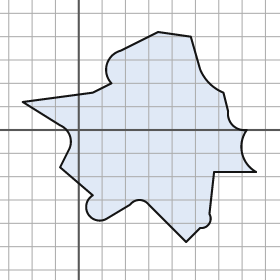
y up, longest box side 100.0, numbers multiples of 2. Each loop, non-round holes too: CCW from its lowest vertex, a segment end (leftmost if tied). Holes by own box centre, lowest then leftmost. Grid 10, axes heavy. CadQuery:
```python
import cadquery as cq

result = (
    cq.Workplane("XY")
    .moveTo(46.0, -48.0)
    .lineTo(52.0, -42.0)
    .threePointArc((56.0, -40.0), (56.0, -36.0))
    .lineTo(58.0, -18.0)
    .lineTo(76.0, -18.0)
    .threePointArc((70.0, -10.0), (72.0, 0.0))
    .threePointArc((66.0, 2.0), (64.0, 8.0))
    .lineTo(62.0, 16.0)
    .threePointArc((56.0, 20.0), (52.0, 26.0))
    .lineTo(48.0, 40.0)
    .lineTo(34.0, 42.0)
    .lineTo(18.0, 34.0)
    .threePointArc((12.0, 28.0), (14.0, 20.0))
    .lineTo(6.0, 16.0)
    .lineTo(-24.0, 12.0)
    .lineTo(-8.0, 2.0)
    .threePointArc((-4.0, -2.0), (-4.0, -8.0))
    .lineTo(-8.0, -16.0)
    .lineTo(6.0, -28.0)
    .threePointArc((4.0, -36.0), (12.0, -38.0))
    .lineTo(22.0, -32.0)
    .threePointArc((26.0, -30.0), (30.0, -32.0))
    .close()
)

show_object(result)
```